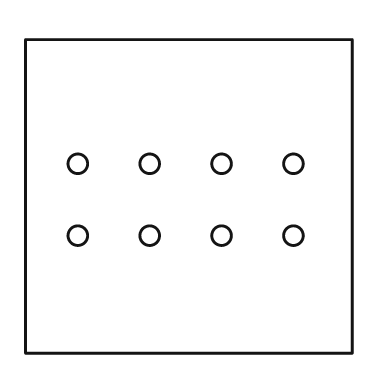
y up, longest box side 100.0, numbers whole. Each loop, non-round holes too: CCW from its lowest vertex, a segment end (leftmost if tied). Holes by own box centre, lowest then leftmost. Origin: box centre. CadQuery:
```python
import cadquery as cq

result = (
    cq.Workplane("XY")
    .moveTo(-50.0, -48.0)
    .lineTo(50.0, -48.0)
    .lineTo(50.0, 48.0)
    .lineTo(-50.0, 48.0)
    .close()
    .moveTo(-34.0, -12.0)
    .circle(3.0)
    .moveTo(-12.0, -12.0)
    .circle(3.0)
    .moveTo(10.0, -12.0)
    .circle(3.0)
    .moveTo(32.0, -12.0)
    .circle(3.0)
    .moveTo(-34.0, 10.0)
    .circle(3.0)
    .moveTo(-12.0, 10.0)
    .circle(3.0)
    .moveTo(10.0, 10.0)
    .circle(3.0)
    .moveTo(32.0, 10.0)
    .circle(3.0)
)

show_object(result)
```